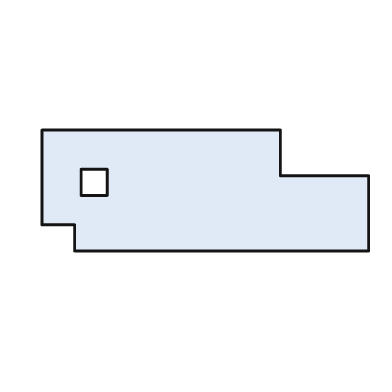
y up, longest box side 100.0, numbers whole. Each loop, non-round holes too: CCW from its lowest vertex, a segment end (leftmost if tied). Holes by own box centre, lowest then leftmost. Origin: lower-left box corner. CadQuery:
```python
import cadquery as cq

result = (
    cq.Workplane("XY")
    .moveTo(10.0, 0.0)
    .lineTo(100.0, 0.0)
    .lineTo(100.0, 23.0)
    .lineTo(73.0, 23.0)
    .lineTo(73.0, 37.0)
    .lineTo(0.0, 37.0)
    .lineTo(0.0, 8.0)
    .lineTo(10.0, 8.0)
    .close()
    .moveTo(12.0, 17.0)
    .lineTo(20.0, 17.0)
    .lineTo(20.0, 25.0)
    .lineTo(12.0, 25.0)
    .close()
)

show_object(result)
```